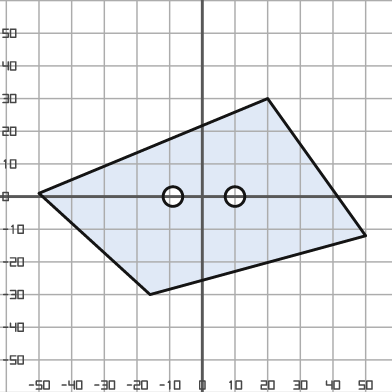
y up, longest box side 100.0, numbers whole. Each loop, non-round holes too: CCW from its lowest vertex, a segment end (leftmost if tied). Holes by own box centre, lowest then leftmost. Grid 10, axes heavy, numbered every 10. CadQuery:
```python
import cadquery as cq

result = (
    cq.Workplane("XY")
    .moveTo(-16.0, -30.0)
    .lineTo(50.0, -12.0)
    .lineTo(20.0, 30.0)
    .lineTo(-50.0, 1.0)
    .close()
    .moveTo(-9.0, 0.0)
    .circle(3.0)
    .moveTo(10.0, 0.0)
    .circle(3.0)
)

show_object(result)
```